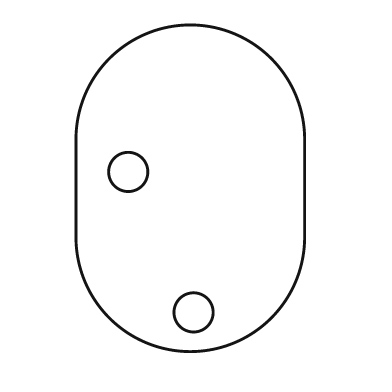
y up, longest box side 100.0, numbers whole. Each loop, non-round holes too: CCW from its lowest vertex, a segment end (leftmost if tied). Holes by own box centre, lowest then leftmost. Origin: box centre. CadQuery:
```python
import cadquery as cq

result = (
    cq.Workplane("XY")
    .moveTo(-35.0, -15.0)
    .threePointArc((0.0, -50.0), (35.0, -15.0))
    .lineTo(35.0, 15.0)
    .threePointArc((0.0, 50.0), (-35.0, 15.0))
    .close()
    .moveTo(1.0, -38.0)
    .circle(6.0)
    .moveTo(-19.0, 5.0)
    .circle(6.0)
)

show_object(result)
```